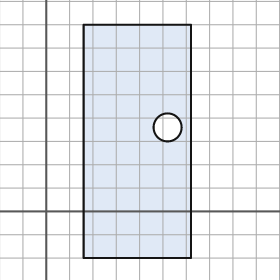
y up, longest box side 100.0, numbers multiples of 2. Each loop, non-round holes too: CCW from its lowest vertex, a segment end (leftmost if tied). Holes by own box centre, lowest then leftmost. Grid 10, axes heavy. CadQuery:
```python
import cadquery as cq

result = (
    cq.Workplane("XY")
    .moveTo(16.0, -20.0)
    .lineTo(62.0, -20.0)
    .lineTo(62.0, 80.0)
    .lineTo(16.0, 80.0)
    .close()
    .moveTo(52.0, 36.0)
    .circle(6.0)
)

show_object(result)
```